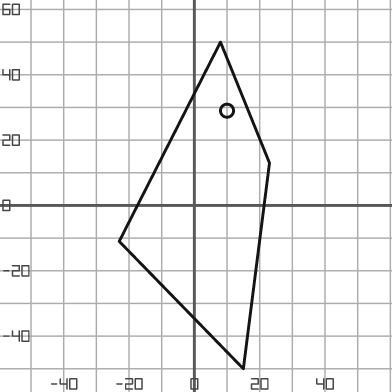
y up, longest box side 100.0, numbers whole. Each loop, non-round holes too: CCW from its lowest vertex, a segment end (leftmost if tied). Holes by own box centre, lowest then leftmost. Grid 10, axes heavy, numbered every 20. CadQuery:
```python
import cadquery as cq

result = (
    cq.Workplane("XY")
    .moveTo(15.0, -50.0)
    .lineTo(23.0, 13.0)
    .lineTo(8.0, 50.0)
    .lineTo(-23.0, -11.0)
    .close()
    .moveTo(10.0, 29.0)
    .circle(2.0)
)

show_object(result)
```